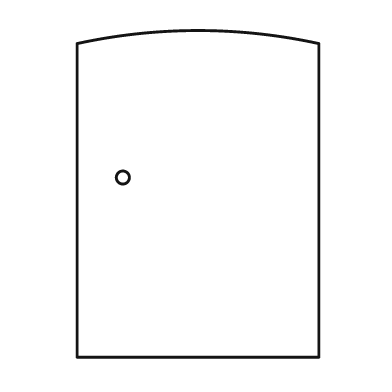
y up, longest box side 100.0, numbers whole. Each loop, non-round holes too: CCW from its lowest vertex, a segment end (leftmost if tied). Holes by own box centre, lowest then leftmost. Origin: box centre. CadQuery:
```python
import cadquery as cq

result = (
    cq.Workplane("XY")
    .moveTo(-37.0, -50.0)
    .lineTo(37.0, -50.0)
    .lineTo(37.0, 46.0)
    .threePointArc((0.0, 50.0), (-37.0, 46.0))
    .close()
    .moveTo(-23.0, 5.0)
    .circle(2.0)
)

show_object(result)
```